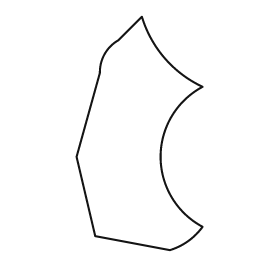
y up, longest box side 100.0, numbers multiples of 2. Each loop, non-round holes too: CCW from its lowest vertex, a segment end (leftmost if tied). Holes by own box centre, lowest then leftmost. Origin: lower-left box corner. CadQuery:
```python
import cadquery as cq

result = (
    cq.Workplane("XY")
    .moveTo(40.0, 0.0)
    .threePointArc((48.0, 4.0), (54.0, 10.0))
    .threePointArc((36.0, 40.0), (54.0, 70.0))
    .threePointArc((38.0, 82.0), (28.0, 100.0))
    .lineTo(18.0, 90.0)
    .threePointArc((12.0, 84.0), (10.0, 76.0))
    .lineTo(0.0, 40.0)
    .lineTo(8.0, 6.0)
    .close()
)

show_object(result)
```